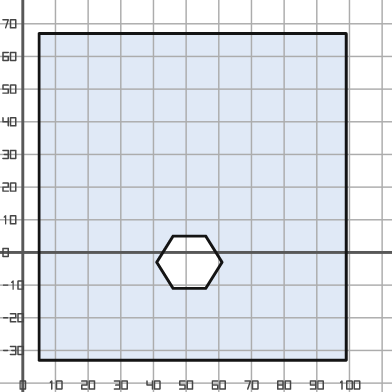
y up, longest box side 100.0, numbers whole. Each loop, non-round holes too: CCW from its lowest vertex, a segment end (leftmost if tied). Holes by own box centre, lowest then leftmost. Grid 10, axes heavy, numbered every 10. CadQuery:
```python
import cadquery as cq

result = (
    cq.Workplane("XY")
    .moveTo(5.0, -33.0)
    .lineTo(99.0, -33.0)
    .lineTo(99.0, 67.0)
    .lineTo(5.0, 67.0)
    .close()
    .moveTo(46.0, -11.0)
    .lineTo(56.0, -11.0)
    .lineTo(61.0, -3.0)
    .lineTo(56.0, 5.0)
    .lineTo(46.0, 5.0)
    .lineTo(41.0, -3.0)
    .close()
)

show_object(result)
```